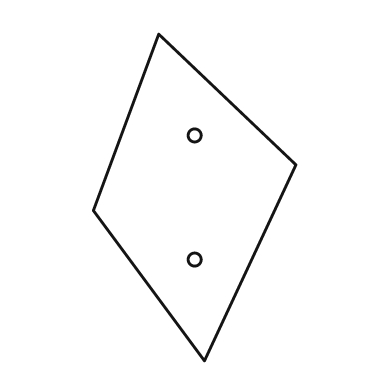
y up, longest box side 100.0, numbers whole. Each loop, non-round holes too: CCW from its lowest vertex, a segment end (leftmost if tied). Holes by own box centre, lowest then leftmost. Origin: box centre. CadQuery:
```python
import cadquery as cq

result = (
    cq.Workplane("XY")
    .moveTo(3.0, -50.0)
    .lineTo(31.0, 10.0)
    .lineTo(-11.0, 50.0)
    .lineTo(-31.0, -4.0)
    .close()
    .moveTo(0.0, -19.0)
    .circle(2.0)
    .moveTo(0.0, 19.0)
    .circle(2.0)
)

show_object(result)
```